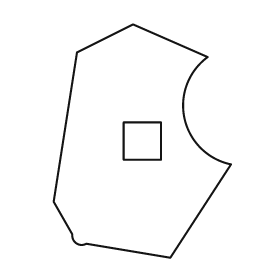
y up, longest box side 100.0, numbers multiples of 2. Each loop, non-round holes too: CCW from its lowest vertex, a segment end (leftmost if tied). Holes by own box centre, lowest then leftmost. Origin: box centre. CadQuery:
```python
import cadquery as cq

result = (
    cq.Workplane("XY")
    .moveTo(12.0, -50.0)
    .lineTo(38.0, -10.0)
    .threePointArc((18.0, 10.0), (28.0, 36.0))
    .lineTo(-4.0, 50.0)
    .lineTo(-28.0, 38.0)
    .lineTo(-38.0, -26.0)
    .lineTo(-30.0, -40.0)
    .threePointArc((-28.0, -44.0), (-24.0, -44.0))
    .close()
    .moveTo(-8.0, -8.0)
    .lineTo(8.0, -8.0)
    .lineTo(8.0, 8.0)
    .lineTo(-8.0, 8.0)
    .close()
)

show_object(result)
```